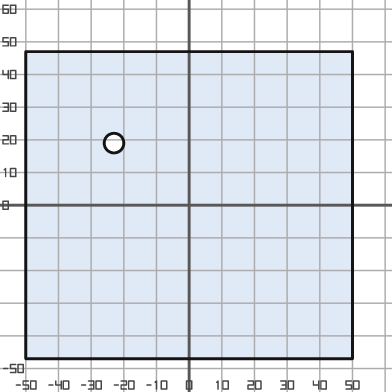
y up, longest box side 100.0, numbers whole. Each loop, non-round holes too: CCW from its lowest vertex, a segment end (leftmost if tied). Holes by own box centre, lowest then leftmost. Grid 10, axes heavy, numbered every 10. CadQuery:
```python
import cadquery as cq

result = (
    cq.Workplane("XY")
    .moveTo(-50.0, -47.0)
    .lineTo(50.0, -47.0)
    .lineTo(50.0, 47.0)
    .lineTo(-50.0, 47.0)
    .close()
    .moveTo(-23.0, 19.0)
    .circle(3.0)
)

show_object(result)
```